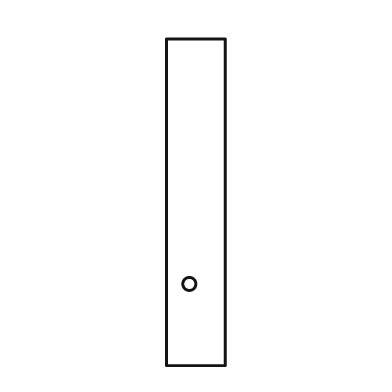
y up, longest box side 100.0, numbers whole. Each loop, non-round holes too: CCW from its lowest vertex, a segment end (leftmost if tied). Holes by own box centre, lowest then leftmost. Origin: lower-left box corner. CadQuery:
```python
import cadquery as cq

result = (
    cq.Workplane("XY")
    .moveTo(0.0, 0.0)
    .lineTo(18.0, 0.0)
    .lineTo(18.0, 100.0)
    .lineTo(0.0, 100.0)
    .close()
    .moveTo(7.0, 25.0)
    .circle(2.0)
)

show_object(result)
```